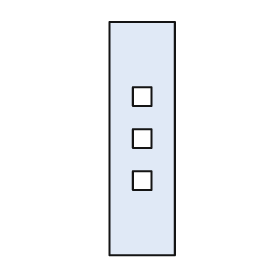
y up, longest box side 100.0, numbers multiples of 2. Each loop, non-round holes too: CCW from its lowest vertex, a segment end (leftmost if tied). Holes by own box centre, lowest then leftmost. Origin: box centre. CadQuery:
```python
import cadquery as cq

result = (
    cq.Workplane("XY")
    .moveTo(-14.0, -50.0)
    .lineTo(14.0, -50.0)
    .lineTo(14.0, 50.0)
    .lineTo(-14.0, 50.0)
    .close()
    .moveTo(-4.0, -22.0)
    .lineTo(4.0, -22.0)
    .lineTo(4.0, -14.0)
    .lineTo(-4.0, -14.0)
    .close()
    .moveTo(-4.0, -4.0)
    .lineTo(4.0, -4.0)
    .lineTo(4.0, 4.0)
    .lineTo(-4.0, 4.0)
    .close()
    .moveTo(-4.0, 14.0)
    .lineTo(4.0, 14.0)
    .lineTo(4.0, 22.0)
    .lineTo(-4.0, 22.0)
    .close()
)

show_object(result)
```